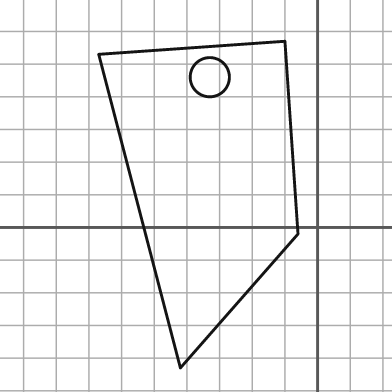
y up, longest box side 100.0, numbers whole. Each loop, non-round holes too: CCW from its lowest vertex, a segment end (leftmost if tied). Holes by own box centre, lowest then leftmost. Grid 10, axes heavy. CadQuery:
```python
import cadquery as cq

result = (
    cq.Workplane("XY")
    .moveTo(-42.0, -43.0)
    .lineTo(-6.0, -2.0)
    .lineTo(-10.0, 57.0)
    .lineTo(-67.0, 53.0)
    .close()
    .moveTo(-33.0, 46.0)
    .circle(6.0)
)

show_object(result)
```